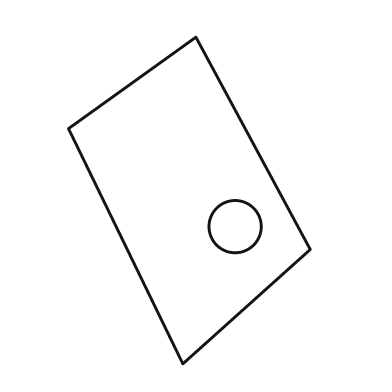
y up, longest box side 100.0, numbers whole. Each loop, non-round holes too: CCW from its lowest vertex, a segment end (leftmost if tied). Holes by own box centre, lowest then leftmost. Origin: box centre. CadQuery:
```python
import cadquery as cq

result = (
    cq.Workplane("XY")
    .moveTo(-2.0, -50.0)
    .lineTo(37.0, -15.0)
    .lineTo(2.0, 50.0)
    .lineTo(-37.0, 22.0)
    .close()
    .moveTo(14.0, -8.0)
    .circle(8.0)
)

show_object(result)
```